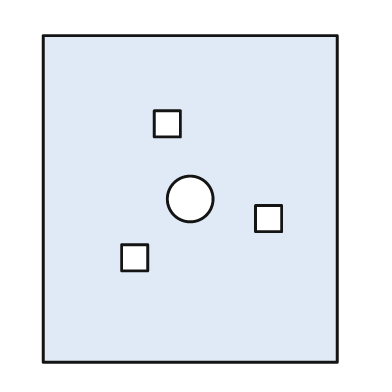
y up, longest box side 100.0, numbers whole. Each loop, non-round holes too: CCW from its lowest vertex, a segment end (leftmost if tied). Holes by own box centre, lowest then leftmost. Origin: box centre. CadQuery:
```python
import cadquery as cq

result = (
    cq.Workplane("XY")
    .moveTo(-45.0, -50.0)
    .lineTo(45.0, -50.0)
    .lineTo(45.0, 50.0)
    .lineTo(-45.0, 50.0)
    .close()
    .moveTo(-21.0, -22.0)
    .lineTo(-13.0, -22.0)
    .lineTo(-13.0, -14.0)
    .lineTo(-21.0, -14.0)
    .close()
    .moveTo(20.0, -10.0)
    .lineTo(28.0, -10.0)
    .lineTo(28.0, -2.0)
    .lineTo(20.0, -2.0)
    .close()
    .moveTo(0.0, 0.0)
    .circle(7.0)
    .moveTo(-11.0, 19.0)
    .lineTo(-3.0, 19.0)
    .lineTo(-3.0, 27.0)
    .lineTo(-11.0, 27.0)
    .close()
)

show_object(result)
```